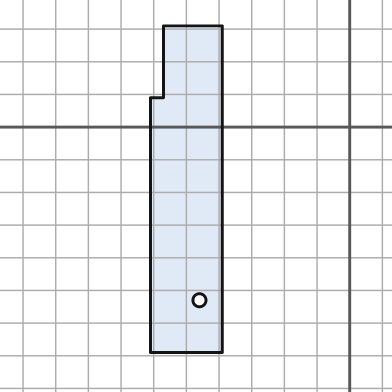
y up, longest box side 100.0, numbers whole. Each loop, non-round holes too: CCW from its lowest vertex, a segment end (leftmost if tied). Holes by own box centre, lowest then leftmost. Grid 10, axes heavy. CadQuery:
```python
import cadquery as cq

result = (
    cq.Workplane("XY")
    .moveTo(-61.0, -69.0)
    .lineTo(-39.0, -69.0)
    .lineTo(-39.0, 31.0)
    .lineTo(-57.0, 31.0)
    .lineTo(-57.0, 9.0)
    .lineTo(-61.0, 9.0)
    .close()
    .moveTo(-46.0, -53.0)
    .circle(2.0)
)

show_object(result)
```